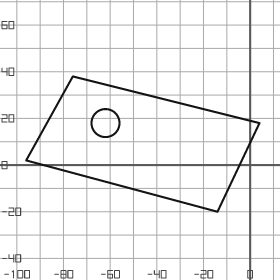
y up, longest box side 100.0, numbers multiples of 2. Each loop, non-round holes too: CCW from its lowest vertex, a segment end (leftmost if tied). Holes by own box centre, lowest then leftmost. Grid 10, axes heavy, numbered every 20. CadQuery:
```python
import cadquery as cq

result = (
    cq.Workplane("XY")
    .moveTo(-14.0, -20.0)
    .lineTo(4.0, 18.0)
    .lineTo(-76.0, 38.0)
    .lineTo(-96.0, 2.0)
    .close()
    .moveTo(-62.0, 18.0)
    .circle(6.0)
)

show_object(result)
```